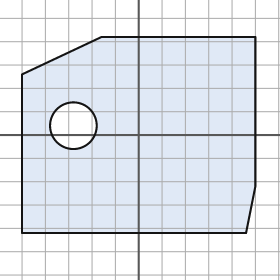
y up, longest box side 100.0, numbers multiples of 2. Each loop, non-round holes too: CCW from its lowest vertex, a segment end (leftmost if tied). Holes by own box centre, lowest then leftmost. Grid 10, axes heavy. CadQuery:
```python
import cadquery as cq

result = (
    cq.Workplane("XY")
    .moveTo(-50.0, -42.0)
    .lineTo(46.0, -42.0)
    .lineTo(50.0, -22.0)
    .lineTo(50.0, 42.0)
    .lineTo(-16.0, 42.0)
    .lineTo(-50.0, 26.0)
    .close()
    .moveTo(-28.0, 4.0)
    .circle(10.0)
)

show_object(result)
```